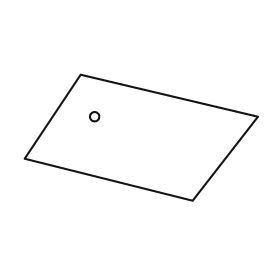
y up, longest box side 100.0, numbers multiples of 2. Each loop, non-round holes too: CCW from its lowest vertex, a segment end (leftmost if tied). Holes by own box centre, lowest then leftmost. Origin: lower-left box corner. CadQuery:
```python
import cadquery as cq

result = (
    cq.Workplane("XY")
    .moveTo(72.0, 0.0)
    .lineTo(100.0, 36.0)
    .lineTo(24.0, 54.0)
    .lineTo(0.0, 18.0)
    .close()
    .moveTo(30.0, 36.0)
    .circle(2.0)
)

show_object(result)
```